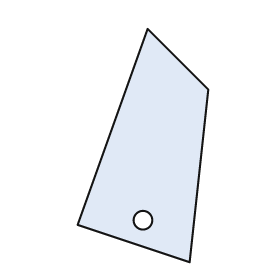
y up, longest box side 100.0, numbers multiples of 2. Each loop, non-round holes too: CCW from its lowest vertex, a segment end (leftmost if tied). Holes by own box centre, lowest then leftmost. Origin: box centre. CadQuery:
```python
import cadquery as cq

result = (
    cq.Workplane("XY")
    .moveTo(20.0, -50.0)
    .lineTo(28.0, 24.0)
    .lineTo(2.0, 50.0)
    .lineTo(-28.0, -34.0)
    .close()
    .moveTo(0.0, -32.0)
    .circle(4.0)
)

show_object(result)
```